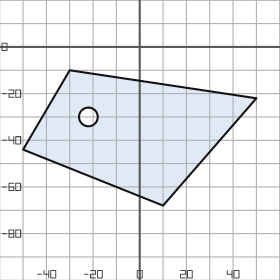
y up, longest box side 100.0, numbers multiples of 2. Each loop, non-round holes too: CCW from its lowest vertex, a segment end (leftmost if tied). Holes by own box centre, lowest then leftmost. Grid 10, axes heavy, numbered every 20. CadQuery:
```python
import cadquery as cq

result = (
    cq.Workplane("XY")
    .moveTo(10.0, -68.0)
    .lineTo(50.0, -22.0)
    .lineTo(-30.0, -10.0)
    .lineTo(-50.0, -44.0)
    .close()
    .moveTo(-22.0, -30.0)
    .circle(4.0)
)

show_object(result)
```